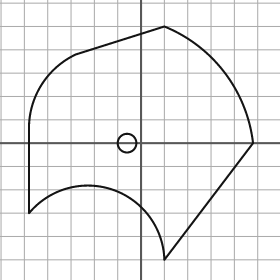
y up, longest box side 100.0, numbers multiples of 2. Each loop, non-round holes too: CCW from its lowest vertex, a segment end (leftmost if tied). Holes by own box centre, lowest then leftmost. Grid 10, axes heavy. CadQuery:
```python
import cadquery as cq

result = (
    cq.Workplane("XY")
    .moveTo(10.0, -50.0)
    .lineTo(48.0, 0.0)
    .threePointArc((36.0, 30.0), (10.0, 50.0))
    .lineTo(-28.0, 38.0)
    .threePointArc((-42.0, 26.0), (-48.0, 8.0))
    .lineTo(-48.0, -30.0)
    .threePointArc((-12.0, -20.0), (10.0, -50.0))
    .close()
    .moveTo(-6.0, 0.0)
    .circle(4.0)
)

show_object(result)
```